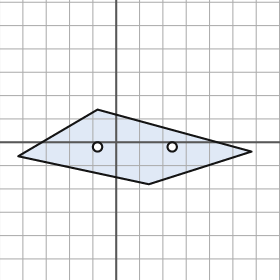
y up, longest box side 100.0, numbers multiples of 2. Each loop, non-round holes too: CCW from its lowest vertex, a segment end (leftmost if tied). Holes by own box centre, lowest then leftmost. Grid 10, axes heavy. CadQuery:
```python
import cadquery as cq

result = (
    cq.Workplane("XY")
    .moveTo(14.0, -18.0)
    .lineTo(58.0, -4.0)
    .lineTo(-8.0, 14.0)
    .lineTo(-42.0, -6.0)
    .close()
    .moveTo(-8.0, -2.0)
    .circle(2.0)
    .moveTo(24.0, -2.0)
    .circle(2.0)
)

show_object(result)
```